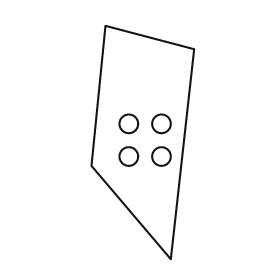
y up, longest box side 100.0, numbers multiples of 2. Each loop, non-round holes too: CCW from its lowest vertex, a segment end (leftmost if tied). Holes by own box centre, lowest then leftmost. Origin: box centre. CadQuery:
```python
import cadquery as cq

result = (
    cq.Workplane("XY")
    .moveTo(12.0, -50.0)
    .lineTo(22.0, 40.0)
    .lineTo(-16.0, 50.0)
    .lineTo(-22.0, -10.0)
    .close()
    .moveTo(-6.0, -6.0)
    .circle(4.0)
    .moveTo(8.0, -6.0)
    .circle(4.0)
    .moveTo(-6.0, 8.0)
    .circle(4.0)
    .moveTo(8.0, 8.0)
    .circle(4.0)
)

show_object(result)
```